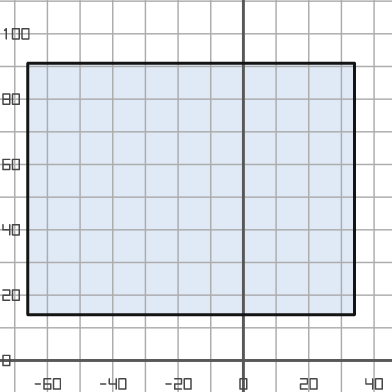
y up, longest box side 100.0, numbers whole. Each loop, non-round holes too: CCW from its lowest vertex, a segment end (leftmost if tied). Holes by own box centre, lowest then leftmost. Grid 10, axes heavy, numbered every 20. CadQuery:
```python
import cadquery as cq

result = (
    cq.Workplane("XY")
    .moveTo(-66.0, 14.0)
    .lineTo(34.0, 14.0)
    .lineTo(34.0, 91.0)
    .lineTo(-66.0, 91.0)
    .close()
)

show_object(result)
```